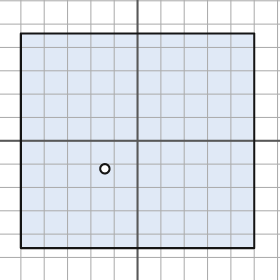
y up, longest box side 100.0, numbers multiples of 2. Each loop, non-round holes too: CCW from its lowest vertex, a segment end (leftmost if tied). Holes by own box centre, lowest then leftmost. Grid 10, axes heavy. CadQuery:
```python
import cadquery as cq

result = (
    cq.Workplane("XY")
    .moveTo(-50.0, -46.0)
    .lineTo(50.0, -46.0)
    .lineTo(50.0, 46.0)
    .lineTo(-50.0, 46.0)
    .close()
    .moveTo(-14.0, -12.0)
    .circle(2.0)
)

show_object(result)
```